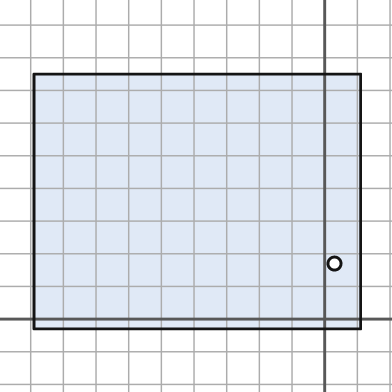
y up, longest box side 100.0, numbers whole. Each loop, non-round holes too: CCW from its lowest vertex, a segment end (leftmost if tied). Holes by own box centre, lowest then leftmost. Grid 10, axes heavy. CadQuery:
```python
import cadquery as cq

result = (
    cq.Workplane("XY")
    .moveTo(-89.0, -3.0)
    .lineTo(11.0, -3.0)
    .lineTo(11.0, 75.0)
    .lineTo(-89.0, 75.0)
    .close()
    .moveTo(3.0, 17.0)
    .circle(2.0)
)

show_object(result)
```